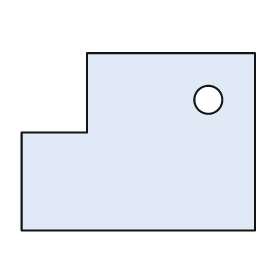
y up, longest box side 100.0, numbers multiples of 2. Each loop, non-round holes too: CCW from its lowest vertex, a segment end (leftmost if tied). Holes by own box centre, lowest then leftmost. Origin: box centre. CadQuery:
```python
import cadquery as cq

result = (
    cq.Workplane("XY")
    .moveTo(-50.0, -38.0)
    .lineTo(50.0, -38.0)
    .lineTo(50.0, 38.0)
    .lineTo(-22.0, 38.0)
    .lineTo(-22.0, 4.0)
    .lineTo(-50.0, 4.0)
    .close()
    .moveTo(30.0, 18.0)
    .circle(6.0)
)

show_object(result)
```